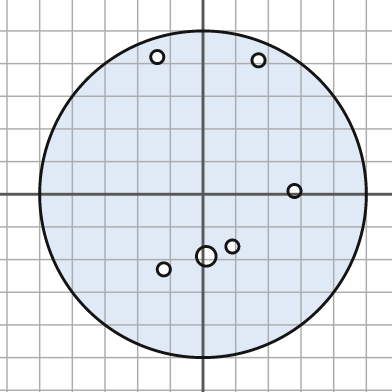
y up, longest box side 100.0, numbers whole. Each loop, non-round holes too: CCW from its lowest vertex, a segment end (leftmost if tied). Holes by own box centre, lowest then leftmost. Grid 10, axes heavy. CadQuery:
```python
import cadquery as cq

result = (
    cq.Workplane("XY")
    .moveTo(0.0, 0.0)
    .circle(50.0)
    .moveTo(-12.0, -23.0)
    .circle(2.0)
    .moveTo(1.0, -19.0)
    .circle(3.0)
    .moveTo(9.0, -16.0)
    .circle(2.0)
    .moveTo(28.0, 1.0)
    .circle(2.0)
    .moveTo(17.0, 41.0)
    .circle(2.0)
    .moveTo(-14.0, 42.0)
    .circle(2.0)
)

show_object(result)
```